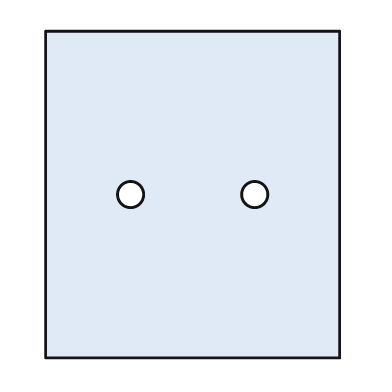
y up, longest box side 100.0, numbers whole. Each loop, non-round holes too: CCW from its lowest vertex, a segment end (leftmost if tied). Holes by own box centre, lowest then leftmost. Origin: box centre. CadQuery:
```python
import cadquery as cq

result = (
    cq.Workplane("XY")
    .moveTo(-45.0, -50.0)
    .lineTo(45.0, -50.0)
    .lineTo(45.0, 50.0)
    .lineTo(-45.0, 50.0)
    .close()
    .moveTo(-19.0, 0.0)
    .circle(4.0)
    .moveTo(19.0, 0.0)
    .circle(4.0)
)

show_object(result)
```